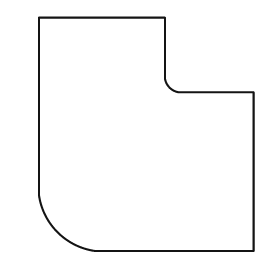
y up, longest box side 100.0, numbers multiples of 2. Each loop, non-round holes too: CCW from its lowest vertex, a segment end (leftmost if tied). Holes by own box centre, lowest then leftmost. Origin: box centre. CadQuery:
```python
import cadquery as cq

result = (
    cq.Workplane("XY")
    .moveTo(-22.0, -50.0)
    .lineTo(46.0, -50.0)
    .lineTo(46.0, 18.0)
    .lineTo(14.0, 18.0)
    .threePointArc((10.0, 20.0), (8.0, 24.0))
    .lineTo(8.0, 50.0)
    .lineTo(-46.0, 50.0)
    .lineTo(-46.0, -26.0)
    .threePointArc((-38.0, -42.0), (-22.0, -50.0))
    .close()
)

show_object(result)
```